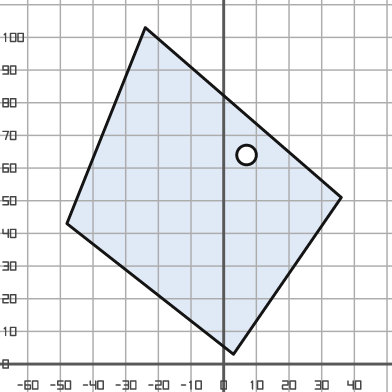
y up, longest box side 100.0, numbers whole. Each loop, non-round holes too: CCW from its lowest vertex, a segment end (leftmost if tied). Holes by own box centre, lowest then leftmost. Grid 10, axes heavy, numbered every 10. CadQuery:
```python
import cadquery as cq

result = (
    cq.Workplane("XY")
    .moveTo(3.0, 3.0)
    .lineTo(36.0, 51.0)
    .lineTo(-24.0, 103.0)
    .lineTo(-48.0, 43.0)
    .close()
    .moveTo(7.0, 64.0)
    .circle(3.0)
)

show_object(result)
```